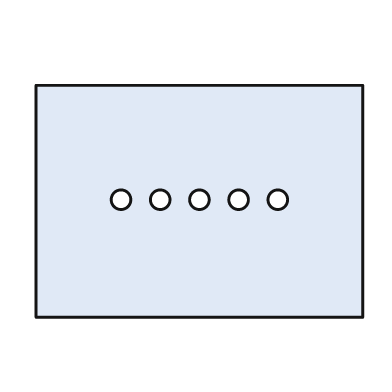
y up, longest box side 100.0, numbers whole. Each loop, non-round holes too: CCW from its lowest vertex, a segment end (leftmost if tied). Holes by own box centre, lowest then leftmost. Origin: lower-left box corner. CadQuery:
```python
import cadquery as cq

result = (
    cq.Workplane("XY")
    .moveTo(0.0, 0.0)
    .lineTo(100.0, 0.0)
    .lineTo(100.0, 71.0)
    .lineTo(0.0, 71.0)
    .close()
    .moveTo(26.0, 36.0)
    .circle(3.0)
    .moveTo(38.0, 36.0)
    .circle(3.0)
    .moveTo(50.0, 36.0)
    .circle(3.0)
    .moveTo(62.0, 36.0)
    .circle(3.0)
    .moveTo(74.0, 36.0)
    .circle(3.0)
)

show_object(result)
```